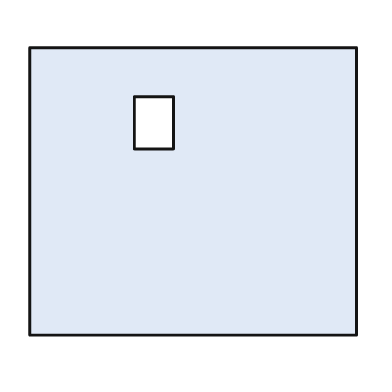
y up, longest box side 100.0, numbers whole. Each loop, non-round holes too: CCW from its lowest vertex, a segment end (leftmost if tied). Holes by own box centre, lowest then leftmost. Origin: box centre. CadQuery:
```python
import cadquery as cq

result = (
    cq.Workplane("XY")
    .moveTo(-50.0, -44.0)
    .lineTo(50.0, -44.0)
    .lineTo(50.0, 44.0)
    .lineTo(-50.0, 44.0)
    .close()
    .moveTo(-18.0, 13.0)
    .lineTo(-6.0, 13.0)
    .lineTo(-6.0, 29.0)
    .lineTo(-18.0, 29.0)
    .close()
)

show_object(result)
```